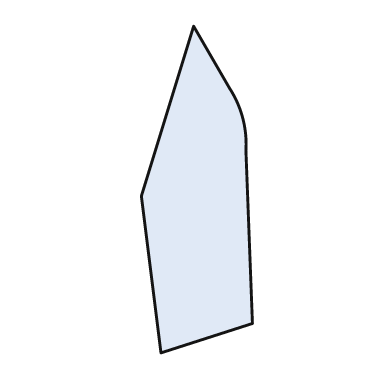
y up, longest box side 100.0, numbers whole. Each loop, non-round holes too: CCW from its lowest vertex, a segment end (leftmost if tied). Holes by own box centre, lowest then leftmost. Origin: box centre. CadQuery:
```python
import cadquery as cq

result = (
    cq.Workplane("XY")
    .moveTo(-11.0, -50.0)
    .lineTo(17.0, -41.0)
    .lineTo(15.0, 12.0)
    .threePointArc((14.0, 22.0), (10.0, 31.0))
    .lineTo(-1.0, 50.0)
    .lineTo(-17.0, -2.0)
    .close()
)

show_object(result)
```